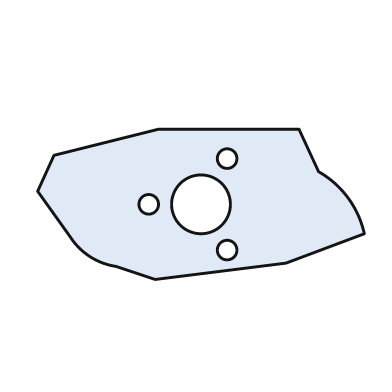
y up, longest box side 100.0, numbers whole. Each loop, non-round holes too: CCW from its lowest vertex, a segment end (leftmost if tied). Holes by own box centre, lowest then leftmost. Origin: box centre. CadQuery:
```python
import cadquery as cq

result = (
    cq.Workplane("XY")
    .moveTo(-14.0, -23.0)
    .lineTo(26.0, -18.0)
    .lineTo(50.0, -9.0)
    .threePointArc((45.0, 2.0), (36.0, 10.0))
    .lineTo(30.0, 23.0)
    .lineTo(-13.0, 23.0)
    .lineTo(-45.0, 15.0)
    .lineTo(-50.0, 4.0)
    .lineTo(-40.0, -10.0)
    .threePointArc((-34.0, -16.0), (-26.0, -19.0))
    .close()
    .moveTo(8.0, -14.0)
    .circle(3.0)
    .moveTo(-16.0, 0.0)
    .circle(3.0)
    .moveTo(0.0, 0.0)
    .circle(9.0)
    .moveTo(8.0, 14.0)
    .circle(3.0)
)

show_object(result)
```